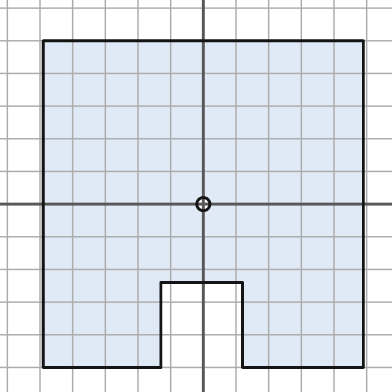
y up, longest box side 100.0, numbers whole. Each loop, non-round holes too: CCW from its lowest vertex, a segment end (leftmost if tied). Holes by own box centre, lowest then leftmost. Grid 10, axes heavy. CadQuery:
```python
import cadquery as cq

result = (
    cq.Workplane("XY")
    .moveTo(-49.0, -50.0)
    .lineTo(-13.0, -50.0)
    .lineTo(-13.0, -24.0)
    .lineTo(12.0, -24.0)
    .lineTo(12.0, -50.0)
    .lineTo(49.0, -50.0)
    .lineTo(49.0, 50.0)
    .lineTo(-49.0, 50.0)
    .close()
    .moveTo(0.0, 0.0)
    .circle(2.0)
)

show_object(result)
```